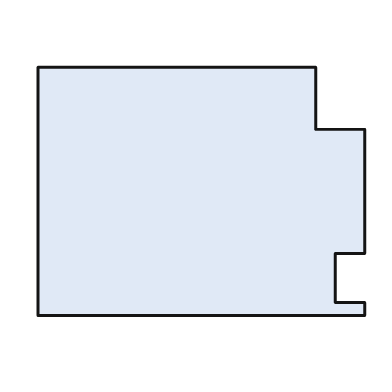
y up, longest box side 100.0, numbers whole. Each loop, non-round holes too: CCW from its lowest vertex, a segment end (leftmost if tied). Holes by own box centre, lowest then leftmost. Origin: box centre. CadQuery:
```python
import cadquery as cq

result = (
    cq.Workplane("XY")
    .moveTo(-50.0, -38.0)
    .lineTo(50.0, -38.0)
    .lineTo(50.0, -34.0)
    .lineTo(41.0, -34.0)
    .lineTo(41.0, -19.0)
    .lineTo(50.0, -19.0)
    .lineTo(50.0, 19.0)
    .lineTo(35.0, 19.0)
    .lineTo(35.0, 38.0)
    .lineTo(-50.0, 38.0)
    .close()
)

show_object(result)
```